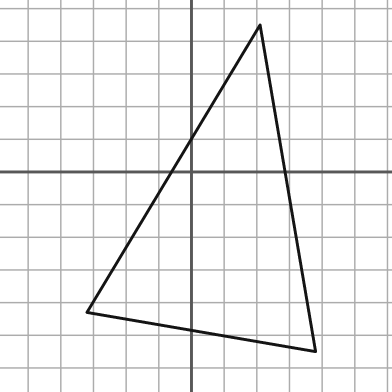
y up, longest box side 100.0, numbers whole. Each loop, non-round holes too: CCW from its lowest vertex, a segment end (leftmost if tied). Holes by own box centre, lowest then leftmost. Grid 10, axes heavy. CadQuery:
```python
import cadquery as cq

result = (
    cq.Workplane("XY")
    .moveTo(38.0, -55.0)
    .lineTo(21.0, 45.0)
    .lineTo(-32.0, -43.0)
    .close()
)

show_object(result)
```